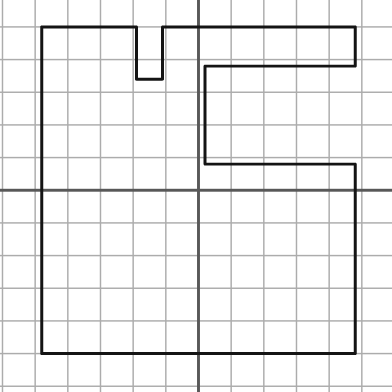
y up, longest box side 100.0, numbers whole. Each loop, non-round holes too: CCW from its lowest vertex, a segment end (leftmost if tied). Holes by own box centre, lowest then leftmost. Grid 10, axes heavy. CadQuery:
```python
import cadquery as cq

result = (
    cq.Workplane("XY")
    .moveTo(-48.0, -50.0)
    .lineTo(48.0, -50.0)
    .lineTo(48.0, 8.0)
    .lineTo(2.0, 8.0)
    .lineTo(2.0, 38.0)
    .lineTo(48.0, 38.0)
    .lineTo(48.0, 50.0)
    .lineTo(-11.0, 50.0)
    .lineTo(-11.0, 34.0)
    .lineTo(-19.0, 34.0)
    .lineTo(-19.0, 50.0)
    .lineTo(-48.0, 50.0)
    .close()
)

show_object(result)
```